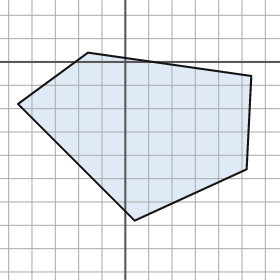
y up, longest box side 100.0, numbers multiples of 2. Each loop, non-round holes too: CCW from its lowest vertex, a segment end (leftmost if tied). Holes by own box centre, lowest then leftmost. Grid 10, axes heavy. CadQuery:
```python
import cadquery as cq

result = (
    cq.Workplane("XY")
    .moveTo(4.0, -68.0)
    .lineTo(52.0, -46.0)
    .lineTo(54.0, -6.0)
    .lineTo(-16.0, 4.0)
    .lineTo(-46.0, -18.0)
    .close()
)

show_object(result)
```